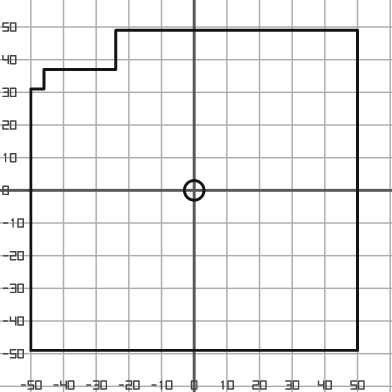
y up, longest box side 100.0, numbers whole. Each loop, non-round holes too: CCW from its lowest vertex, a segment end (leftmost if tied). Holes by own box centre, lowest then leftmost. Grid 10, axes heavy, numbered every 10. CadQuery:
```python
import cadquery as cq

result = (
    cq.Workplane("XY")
    .moveTo(-50.0, -49.0)
    .lineTo(50.0, -49.0)
    .lineTo(50.0, 49.0)
    .lineTo(-24.0, 49.0)
    .lineTo(-24.0, 37.0)
    .lineTo(-46.0, 37.0)
    .lineTo(-46.0, 31.0)
    .lineTo(-50.0, 31.0)
    .close()
    .moveTo(0.0, 0.0)
    .circle(3.0)
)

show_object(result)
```